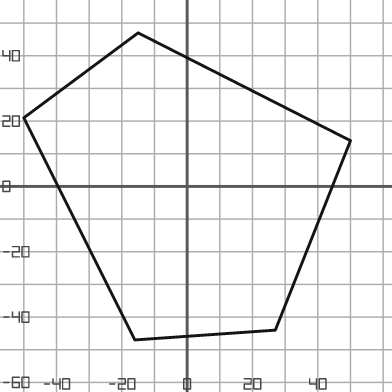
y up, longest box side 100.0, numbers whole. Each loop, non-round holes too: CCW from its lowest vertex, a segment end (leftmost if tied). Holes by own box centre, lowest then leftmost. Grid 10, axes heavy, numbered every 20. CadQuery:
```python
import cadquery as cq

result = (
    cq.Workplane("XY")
    .moveTo(-16.0, -47.0)
    .lineTo(27.0, -44.0)
    .lineTo(50.0, 14.0)
    .lineTo(-15.0, 47.0)
    .lineTo(-50.0, 21.0)
    .close()
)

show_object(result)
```